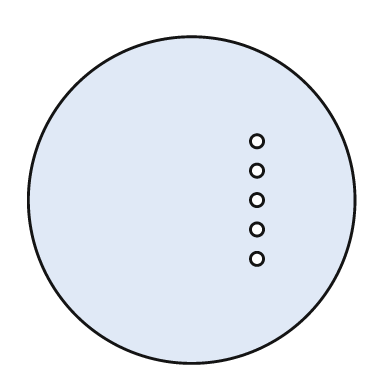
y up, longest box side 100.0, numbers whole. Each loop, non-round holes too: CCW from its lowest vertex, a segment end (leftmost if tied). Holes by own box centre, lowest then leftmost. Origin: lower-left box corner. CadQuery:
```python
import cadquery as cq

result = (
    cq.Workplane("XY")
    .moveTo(50.0, 50.0)
    .circle(50.0)
    .moveTo(70.0, 32.0)
    .circle(2.0)
    .moveTo(70.0, 41.0)
    .circle(2.0)
    .moveTo(70.0, 50.0)
    .circle(2.0)
    .moveTo(70.0, 59.0)
    .circle(2.0)
    .moveTo(70.0, 68.0)
    .circle(2.0)
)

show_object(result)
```